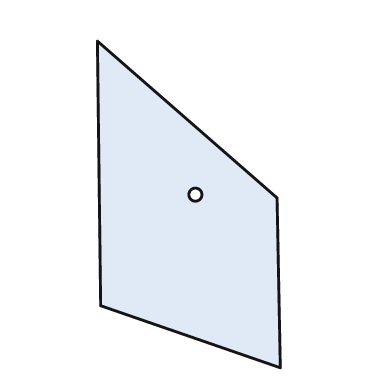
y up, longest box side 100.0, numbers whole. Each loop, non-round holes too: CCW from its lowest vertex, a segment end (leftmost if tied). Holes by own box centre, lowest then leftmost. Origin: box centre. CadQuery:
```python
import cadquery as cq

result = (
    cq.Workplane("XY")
    .moveTo(28.0, -50.0)
    .lineTo(27.0, 2.0)
    .lineTo(-28.0, 50.0)
    .lineTo(-27.0, -31.0)
    .close()
    .moveTo(2.0, 3.0)
    .circle(2.0)
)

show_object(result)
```